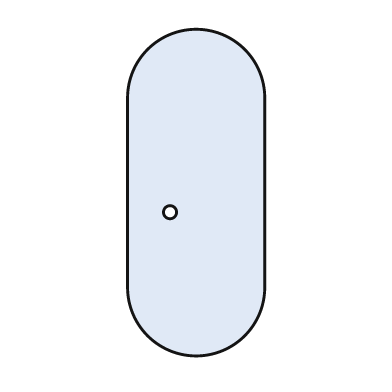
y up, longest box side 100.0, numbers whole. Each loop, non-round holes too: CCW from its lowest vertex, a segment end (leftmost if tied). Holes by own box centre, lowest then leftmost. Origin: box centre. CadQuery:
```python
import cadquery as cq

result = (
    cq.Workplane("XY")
    .moveTo(-21.0, -29.0)
    .threePointArc((0.0, -50.0), (21.0, -29.0))
    .lineTo(21.0, 29.0)
    .threePointArc((0.0, 50.0), (-21.0, 29.0))
    .close()
    .moveTo(-8.0, -6.0)
    .circle(2.0)
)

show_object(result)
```